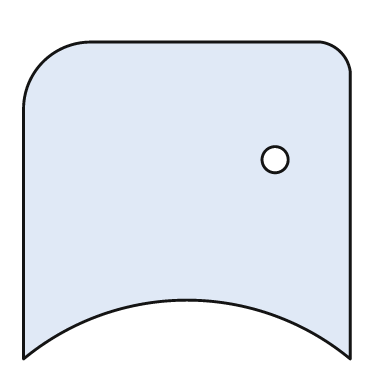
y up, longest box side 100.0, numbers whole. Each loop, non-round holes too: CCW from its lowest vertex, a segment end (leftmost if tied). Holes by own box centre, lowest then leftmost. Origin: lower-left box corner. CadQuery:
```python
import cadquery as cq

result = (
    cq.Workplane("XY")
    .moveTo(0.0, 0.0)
    .threePointArc((50.0, 18.0), (100.0, 0.0))
    .lineTo(100.0, 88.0)
    .threePointArc((97.0, 94.0), (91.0, 97.0))
    .lineTo(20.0, 97.0)
    .threePointArc((6.0, 91.0), (0.0, 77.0))
    .close()
    .moveTo(77.0, 61.0)
    .circle(4.0)
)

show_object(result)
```